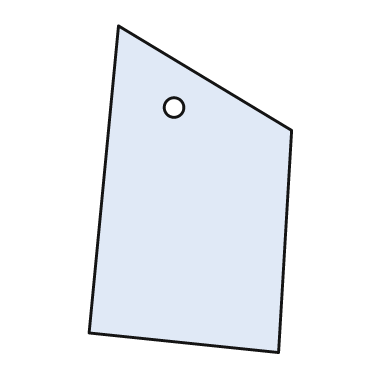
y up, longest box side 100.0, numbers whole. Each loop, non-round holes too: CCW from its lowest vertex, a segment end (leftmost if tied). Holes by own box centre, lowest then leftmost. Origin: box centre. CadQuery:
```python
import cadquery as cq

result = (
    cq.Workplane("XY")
    .moveTo(27.0, -50.0)
    .lineTo(31.0, 18.0)
    .lineTo(-22.0, 50.0)
    .lineTo(-31.0, -44.0)
    .close()
    .moveTo(-5.0, 25.0)
    .circle(3.0)
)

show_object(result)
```